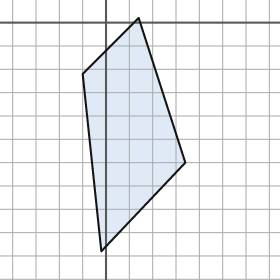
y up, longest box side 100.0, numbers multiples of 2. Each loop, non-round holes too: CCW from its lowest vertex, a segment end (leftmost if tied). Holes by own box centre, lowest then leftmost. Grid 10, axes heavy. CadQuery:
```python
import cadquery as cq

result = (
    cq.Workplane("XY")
    .moveTo(-2.0, -98.0)
    .lineTo(34.0, -60.0)
    .lineTo(14.0, 2.0)
    .lineTo(-10.0, -22.0)
    .close()
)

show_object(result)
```